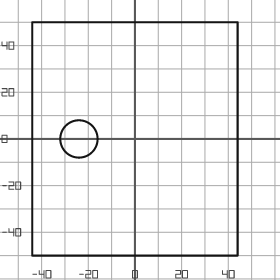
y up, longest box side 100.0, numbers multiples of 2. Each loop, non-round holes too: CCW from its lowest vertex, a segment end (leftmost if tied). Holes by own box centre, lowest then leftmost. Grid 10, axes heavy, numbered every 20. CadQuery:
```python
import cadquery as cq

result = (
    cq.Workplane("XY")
    .moveTo(-44.0, -50.0)
    .lineTo(44.0, -50.0)
    .lineTo(44.0, 50.0)
    .lineTo(-44.0, 50.0)
    .close()
    .moveTo(-24.0, 0.0)
    .circle(8.0)
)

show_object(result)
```